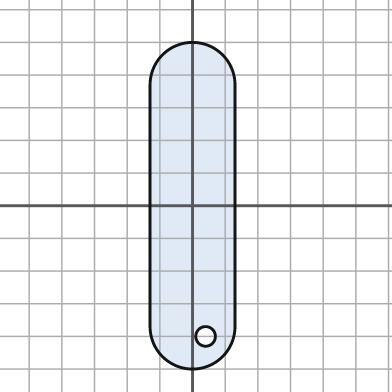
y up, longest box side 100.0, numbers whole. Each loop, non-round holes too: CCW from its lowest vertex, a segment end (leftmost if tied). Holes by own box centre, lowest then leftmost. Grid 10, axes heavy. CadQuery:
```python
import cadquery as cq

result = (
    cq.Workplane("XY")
    .moveTo(-13.0, -37.0)
    .threePointArc((0.0, -50.0), (13.0, -37.0))
    .lineTo(13.0, 37.0)
    .threePointArc((0.0, 50.0), (-13.0, 37.0))
    .close()
    .moveTo(4.0, -40.0)
    .circle(3.0)
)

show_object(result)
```